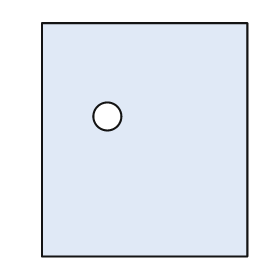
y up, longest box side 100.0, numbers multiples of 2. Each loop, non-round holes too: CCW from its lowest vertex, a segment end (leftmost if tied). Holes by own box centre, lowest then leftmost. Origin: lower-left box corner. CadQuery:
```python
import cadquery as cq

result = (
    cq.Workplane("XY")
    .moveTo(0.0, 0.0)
    .lineTo(88.0, 0.0)
    .lineTo(88.0, 100.0)
    .lineTo(0.0, 100.0)
    .close()
    .moveTo(28.0, 60.0)
    .circle(6.0)
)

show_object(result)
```